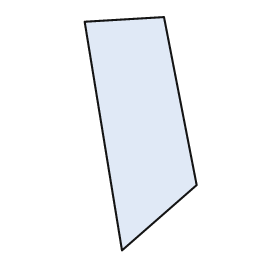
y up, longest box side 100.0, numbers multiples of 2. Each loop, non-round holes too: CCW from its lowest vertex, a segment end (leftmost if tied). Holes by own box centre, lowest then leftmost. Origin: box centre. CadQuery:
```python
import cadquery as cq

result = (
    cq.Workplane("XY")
    .moveTo(-8.0, -50.0)
    .lineTo(24.0, -22.0)
    .lineTo(10.0, 50.0)
    .lineTo(-24.0, 48.0)
    .close()
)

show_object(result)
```